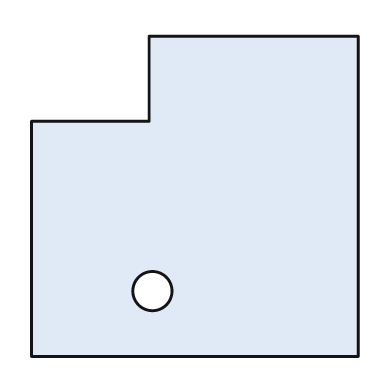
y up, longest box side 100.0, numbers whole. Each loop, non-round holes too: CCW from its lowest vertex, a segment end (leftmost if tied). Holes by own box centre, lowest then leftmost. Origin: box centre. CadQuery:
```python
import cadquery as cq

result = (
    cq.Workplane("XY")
    .moveTo(-50.0, -49.0)
    .lineTo(50.0, -49.0)
    .lineTo(50.0, 49.0)
    .lineTo(-14.0, 49.0)
    .lineTo(-14.0, 23.0)
    .lineTo(-50.0, 23.0)
    .close()
    .moveTo(-13.0, -29.0)
    .circle(6.0)
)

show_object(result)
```